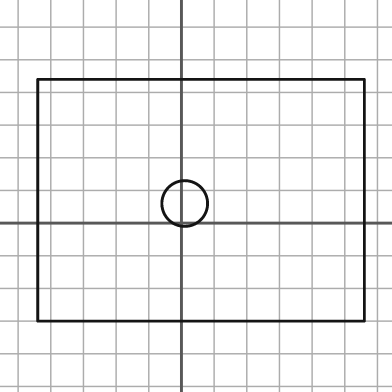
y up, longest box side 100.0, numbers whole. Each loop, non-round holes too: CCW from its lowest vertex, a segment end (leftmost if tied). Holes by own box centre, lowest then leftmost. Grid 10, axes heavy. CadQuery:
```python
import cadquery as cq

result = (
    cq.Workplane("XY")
    .moveTo(-44.0, -30.0)
    .lineTo(56.0, -30.0)
    .lineTo(56.0, 44.0)
    .lineTo(-44.0, 44.0)
    .close()
    .moveTo(1.0, 6.0)
    .circle(7.0)
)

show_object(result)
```